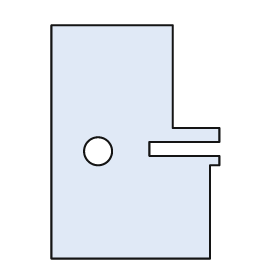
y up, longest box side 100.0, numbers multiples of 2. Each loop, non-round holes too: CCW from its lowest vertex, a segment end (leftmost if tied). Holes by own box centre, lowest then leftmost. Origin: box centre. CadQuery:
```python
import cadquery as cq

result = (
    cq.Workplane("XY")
    .moveTo(-36.0, -50.0)
    .lineTo(32.0, -50.0)
    .lineTo(32.0, -10.0)
    .lineTo(36.0, -10.0)
    .lineTo(36.0, -6.0)
    .lineTo(6.0, -6.0)
    .lineTo(6.0, 0.0)
    .lineTo(36.0, 0.0)
    .lineTo(36.0, 6.0)
    .lineTo(16.0, 6.0)
    .lineTo(16.0, 50.0)
    .lineTo(-36.0, 50.0)
    .close()
    .moveTo(-16.0, -4.0)
    .circle(6.0)
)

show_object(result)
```